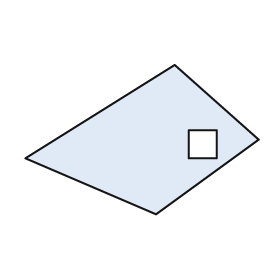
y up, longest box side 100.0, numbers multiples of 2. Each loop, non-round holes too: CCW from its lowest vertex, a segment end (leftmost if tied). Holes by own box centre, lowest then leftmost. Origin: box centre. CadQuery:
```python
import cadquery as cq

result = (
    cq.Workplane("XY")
    .moveTo(6.0, -32.0)
    .lineTo(50.0, 0.0)
    .lineTo(14.0, 32.0)
    .lineTo(-50.0, -8.0)
    .close()
    .moveTo(20.0, -8.0)
    .lineTo(32.0, -8.0)
    .lineTo(32.0, 4.0)
    .lineTo(20.0, 4.0)
    .close()
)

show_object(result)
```